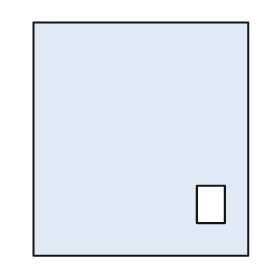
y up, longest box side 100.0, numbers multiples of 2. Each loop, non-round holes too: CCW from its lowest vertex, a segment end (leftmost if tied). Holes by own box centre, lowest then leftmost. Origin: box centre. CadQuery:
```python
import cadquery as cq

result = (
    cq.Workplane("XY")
    .moveTo(-46.0, -50.0)
    .lineTo(46.0, -50.0)
    .lineTo(46.0, 50.0)
    .lineTo(-46.0, 50.0)
    .close()
    .moveTo(24.0, -36.0)
    .lineTo(36.0, -36.0)
    .lineTo(36.0, -20.0)
    .lineTo(24.0, -20.0)
    .close()
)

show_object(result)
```